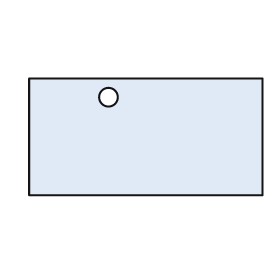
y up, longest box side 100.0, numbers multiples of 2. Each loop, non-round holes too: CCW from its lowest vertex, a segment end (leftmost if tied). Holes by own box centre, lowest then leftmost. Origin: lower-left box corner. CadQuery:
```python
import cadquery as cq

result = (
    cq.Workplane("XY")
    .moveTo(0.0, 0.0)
    .lineTo(100.0, 0.0)
    .lineTo(100.0, 50.0)
    .lineTo(0.0, 50.0)
    .close()
    .moveTo(34.0, 42.0)
    .circle(4.0)
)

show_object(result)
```